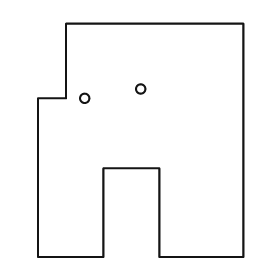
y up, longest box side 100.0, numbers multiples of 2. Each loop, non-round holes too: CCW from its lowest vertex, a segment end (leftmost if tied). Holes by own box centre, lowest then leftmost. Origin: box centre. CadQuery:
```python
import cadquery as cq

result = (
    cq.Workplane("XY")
    .moveTo(-44.0, -50.0)
    .lineTo(-16.0, -50.0)
    .lineTo(-16.0, -12.0)
    .lineTo(8.0, -12.0)
    .lineTo(8.0, -50.0)
    .lineTo(44.0, -50.0)
    .lineTo(44.0, 50.0)
    .lineTo(-32.0, 50.0)
    .lineTo(-32.0, 18.0)
    .lineTo(-44.0, 18.0)
    .close()
    .moveTo(-24.0, 18.0)
    .circle(2.0)
    .moveTo(0.0, 22.0)
    .circle(2.0)
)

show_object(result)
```